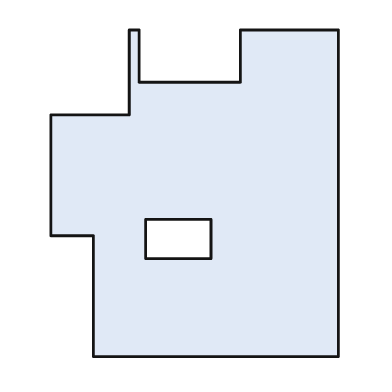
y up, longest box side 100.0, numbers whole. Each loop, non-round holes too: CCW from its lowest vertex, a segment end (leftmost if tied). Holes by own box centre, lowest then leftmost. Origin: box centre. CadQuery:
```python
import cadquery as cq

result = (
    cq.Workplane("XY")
    .moveTo(-31.0, -50.0)
    .lineTo(44.0, -50.0)
    .lineTo(44.0, 50.0)
    .lineTo(14.0, 50.0)
    .lineTo(14.0, 34.0)
    .lineTo(-17.0, 34.0)
    .lineTo(-17.0, 50.0)
    .lineTo(-20.0, 50.0)
    .lineTo(-20.0, 24.0)
    .lineTo(-44.0, 24.0)
    .lineTo(-44.0, -13.0)
    .lineTo(-31.0, -13.0)
    .close()
    .moveTo(-15.0, -20.0)
    .lineTo(5.0, -20.0)
    .lineTo(5.0, -8.0)
    .lineTo(-15.0, -8.0)
    .close()
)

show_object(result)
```